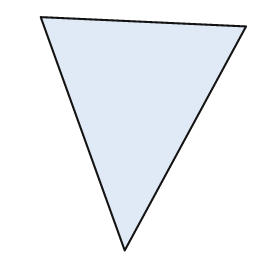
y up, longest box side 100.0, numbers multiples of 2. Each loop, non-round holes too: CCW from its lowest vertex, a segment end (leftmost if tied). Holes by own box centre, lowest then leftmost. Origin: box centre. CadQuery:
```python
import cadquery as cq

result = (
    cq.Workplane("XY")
    .moveTo(-8.0, -50.0)
    .lineTo(44.0, 46.0)
    .lineTo(-44.0, 50.0)
    .close()
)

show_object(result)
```